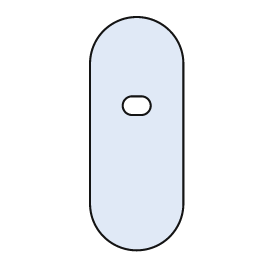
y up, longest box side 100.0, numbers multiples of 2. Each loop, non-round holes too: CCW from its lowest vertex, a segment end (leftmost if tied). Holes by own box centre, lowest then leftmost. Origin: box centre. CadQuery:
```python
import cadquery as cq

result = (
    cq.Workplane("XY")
    .moveTo(-20.0, -30.0)
    .threePointArc((0.0, -50.0), (20.0, -30.0))
    .lineTo(20.0, 30.0)
    .threePointArc((0.0, 50.0), (-20.0, 30.0))
    .close()
    .moveTo(-2.0, 8.0)
    .lineTo(2.0, 8.0)
    .threePointArc((6.0, 12.0), (2.0, 16.0))
    .lineTo(-2.0, 16.0)
    .threePointArc((-6.0, 12.0), (-2.0, 8.0))
    .close()
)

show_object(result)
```